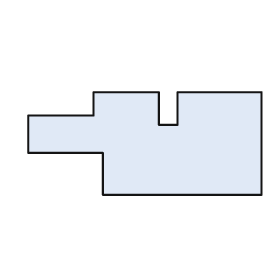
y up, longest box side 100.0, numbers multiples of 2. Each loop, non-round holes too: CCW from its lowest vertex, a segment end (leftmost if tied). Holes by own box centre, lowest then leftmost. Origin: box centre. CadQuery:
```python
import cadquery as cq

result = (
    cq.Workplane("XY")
    .moveTo(-18.0, -22.0)
    .lineTo(50.0, -22.0)
    .lineTo(50.0, 22.0)
    .lineTo(14.0, 22.0)
    .lineTo(14.0, 8.0)
    .lineTo(6.0, 8.0)
    .lineTo(6.0, 22.0)
    .lineTo(-22.0, 22.0)
    .lineTo(-22.0, 12.0)
    .lineTo(-50.0, 12.0)
    .lineTo(-50.0, -4.0)
    .lineTo(-18.0, -4.0)
    .close()
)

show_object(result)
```